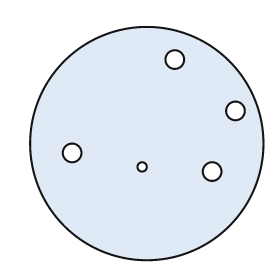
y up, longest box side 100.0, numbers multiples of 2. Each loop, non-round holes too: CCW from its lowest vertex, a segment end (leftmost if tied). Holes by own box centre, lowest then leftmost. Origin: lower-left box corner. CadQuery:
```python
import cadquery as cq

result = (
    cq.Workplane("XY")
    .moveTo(50.0, 50.0)
    .circle(50.0)
    .moveTo(78.0, 38.0)
    .circle(4.0)
    .moveTo(48.0, 40.0)
    .circle(2.0)
    .moveTo(18.0, 46.0)
    .circle(4.0)
    .moveTo(88.0, 64.0)
    .circle(4.0)
    .moveTo(62.0, 86.0)
    .circle(4.0)
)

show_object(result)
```